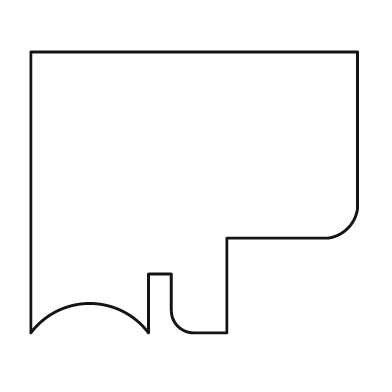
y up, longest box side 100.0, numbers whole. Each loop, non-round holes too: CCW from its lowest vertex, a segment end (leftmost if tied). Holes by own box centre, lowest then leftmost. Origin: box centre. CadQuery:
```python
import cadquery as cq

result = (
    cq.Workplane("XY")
    .moveTo(-50.0, -43.0)
    .threePointArc((-32.0, -34.0), (-14.0, -43.0))
    .lineTo(-14.0, -25.0)
    .lineTo(-7.0, -25.0)
    .lineTo(-7.0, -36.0)
    .threePointArc((-5.0, -41.0), (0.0, -43.0))
    .lineTo(10.0, -43.0)
    .lineTo(10.0, -14.0)
    .lineTo(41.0, -14.0)
    .threePointArc((47.0, -11.0), (50.0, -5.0))
    .lineTo(50.0, 43.0)
    .lineTo(-50.0, 43.0)
    .close()
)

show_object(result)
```